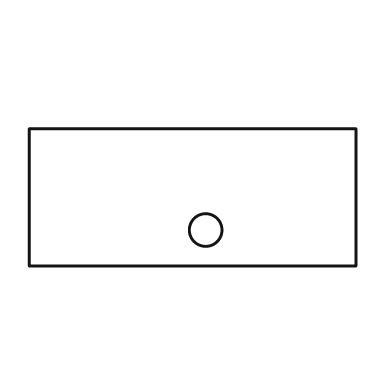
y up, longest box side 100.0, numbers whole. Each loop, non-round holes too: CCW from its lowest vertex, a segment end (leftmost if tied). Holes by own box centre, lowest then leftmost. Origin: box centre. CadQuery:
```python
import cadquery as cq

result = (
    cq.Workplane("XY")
    .moveTo(-50.0, -21.0)
    .lineTo(50.0, -21.0)
    .lineTo(50.0, 21.0)
    .lineTo(-50.0, 21.0)
    .close()
    .moveTo(4.0, -10.0)
    .circle(5.0)
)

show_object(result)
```